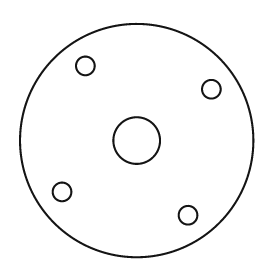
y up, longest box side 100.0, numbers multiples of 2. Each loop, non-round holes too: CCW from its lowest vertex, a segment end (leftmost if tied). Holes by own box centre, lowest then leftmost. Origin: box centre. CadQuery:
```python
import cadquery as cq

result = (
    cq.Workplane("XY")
    .moveTo(0.0, 0.0)
    .circle(50.0)
    .moveTo(22.0, -32.0)
    .circle(4.0)
    .moveTo(-32.0, -22.0)
    .circle(4.0)
    .moveTo(0.0, 0.0)
    .circle(10.0)
    .moveTo(32.0, 22.0)
    .circle(4.0)
    .moveTo(-22.0, 32.0)
    .circle(4.0)
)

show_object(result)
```